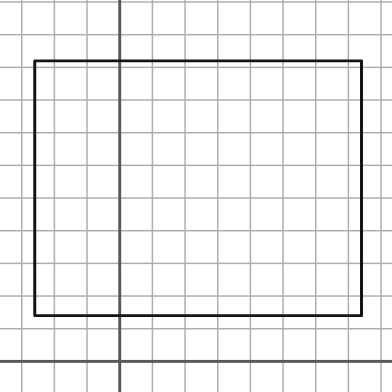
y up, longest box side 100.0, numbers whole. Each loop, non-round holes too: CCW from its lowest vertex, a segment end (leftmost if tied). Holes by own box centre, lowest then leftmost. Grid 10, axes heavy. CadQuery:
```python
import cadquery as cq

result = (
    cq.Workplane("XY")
    .moveTo(-26.0, 14.0)
    .lineTo(74.0, 14.0)
    .lineTo(74.0, 92.0)
    .lineTo(-26.0, 92.0)
    .close()
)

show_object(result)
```